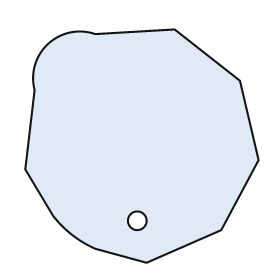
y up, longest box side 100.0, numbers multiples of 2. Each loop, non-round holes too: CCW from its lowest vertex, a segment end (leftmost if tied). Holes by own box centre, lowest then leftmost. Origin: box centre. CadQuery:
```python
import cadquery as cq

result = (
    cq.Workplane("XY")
    .moveTo(2.0, -50.0)
    .lineTo(34.0, -36.0)
    .lineTo(50.0, -6.0)
    .lineTo(42.0, 28.0)
    .lineTo(14.0, 50.0)
    .lineTo(-20.0, 48.0)
    .threePointArc((-40.0, 44.0), (-46.0, 24.0))
    .lineTo(-50.0, -10.0)
    .lineTo(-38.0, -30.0)
    .threePointArc((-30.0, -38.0), (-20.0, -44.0))
    .close()
    .moveTo(-2.0, -32.0)
    .circle(4.0)
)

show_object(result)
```